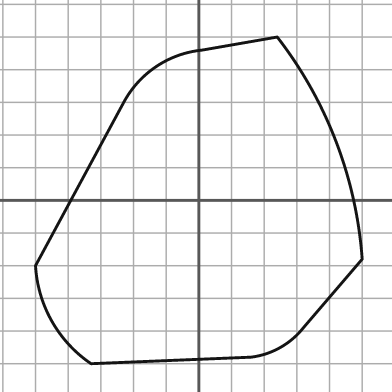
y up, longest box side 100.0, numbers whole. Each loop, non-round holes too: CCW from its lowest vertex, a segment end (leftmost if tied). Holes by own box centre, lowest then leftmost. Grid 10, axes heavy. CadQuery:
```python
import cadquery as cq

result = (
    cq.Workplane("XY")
    .moveTo(-33.0, -50.0)
    .lineTo(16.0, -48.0)
    .threePointArc((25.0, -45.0), (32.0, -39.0))
    .lineTo(50.0, -18.0)
    .threePointArc((42.0, 18.0), (24.0, 50.0))
    .lineTo(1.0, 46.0)
    .threePointArc((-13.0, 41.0), (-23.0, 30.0))
    .lineTo(-50.0, -20.0)
    .threePointArc((-45.0, -37.0), (-33.0, -50.0))
    .close()
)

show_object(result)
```